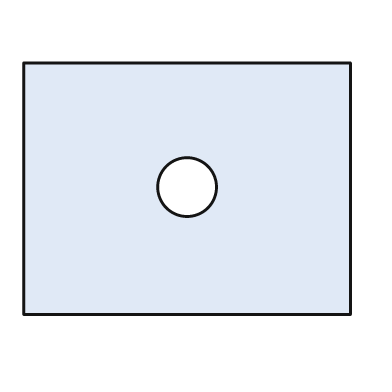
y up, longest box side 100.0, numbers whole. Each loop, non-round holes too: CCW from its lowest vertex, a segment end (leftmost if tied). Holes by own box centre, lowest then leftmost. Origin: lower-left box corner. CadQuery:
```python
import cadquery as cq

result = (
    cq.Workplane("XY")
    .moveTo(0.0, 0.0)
    .lineTo(100.0, 0.0)
    .lineTo(100.0, 77.0)
    .lineTo(0.0, 77.0)
    .close()
    .moveTo(50.0, 39.0)
    .circle(9.0)
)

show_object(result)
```